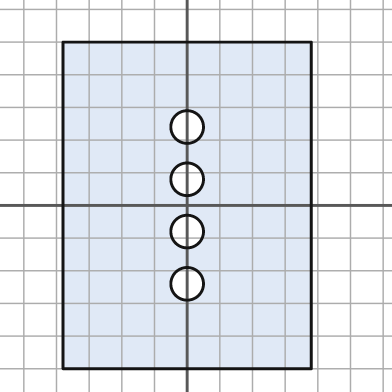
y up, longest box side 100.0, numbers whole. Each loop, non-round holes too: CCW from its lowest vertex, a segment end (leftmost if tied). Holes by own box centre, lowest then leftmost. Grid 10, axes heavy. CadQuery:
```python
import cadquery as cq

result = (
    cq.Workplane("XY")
    .moveTo(-38.0, -50.0)
    .lineTo(38.0, -50.0)
    .lineTo(38.0, 50.0)
    .lineTo(-38.0, 50.0)
    .close()
    .moveTo(0.0, -24.0)
    .circle(5.0)
    .moveTo(0.0, -8.0)
    .circle(5.0)
    .moveTo(0.0, 8.0)
    .circle(5.0)
    .moveTo(0.0, 24.0)
    .circle(5.0)
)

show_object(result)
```